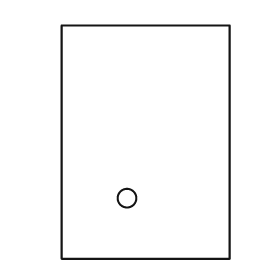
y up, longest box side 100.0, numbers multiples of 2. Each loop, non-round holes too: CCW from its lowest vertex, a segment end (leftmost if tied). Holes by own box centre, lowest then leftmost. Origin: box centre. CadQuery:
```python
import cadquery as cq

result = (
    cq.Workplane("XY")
    .moveTo(-36.0, -50.0)
    .lineTo(36.0, -50.0)
    .lineTo(36.0, 50.0)
    .lineTo(-36.0, 50.0)
    .close()
    .moveTo(-8.0, -24.0)
    .circle(4.0)
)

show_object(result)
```